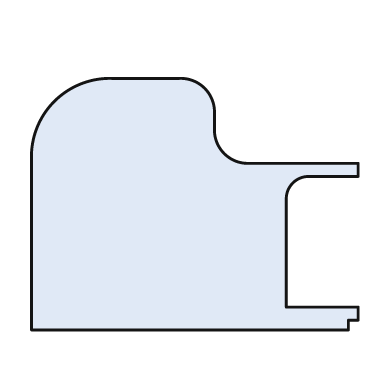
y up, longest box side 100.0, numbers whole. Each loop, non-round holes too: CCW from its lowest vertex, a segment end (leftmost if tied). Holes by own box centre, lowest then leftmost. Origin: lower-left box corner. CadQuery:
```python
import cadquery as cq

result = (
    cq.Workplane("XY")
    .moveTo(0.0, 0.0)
    .lineTo(97.0, 0.0)
    .lineTo(97.0, 3.0)
    .lineTo(100.0, 3.0)
    .lineTo(100.0, 7.0)
    .lineTo(78.0, 7.0)
    .lineTo(78.0, 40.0)
    .threePointArc((80.0, 45.0), (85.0, 47.0))
    .lineTo(100.0, 47.0)
    .lineTo(100.0, 51.0)
    .lineTo(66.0, 51.0)
    .threePointArc((59.0, 54.0), (56.0, 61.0))
    .lineTo(56.0, 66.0)
    .threePointArc((53.0, 74.0), (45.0, 77.0))
    .lineTo(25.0, 77.0)
    .threePointArc((7.0, 70.0), (0.0, 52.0))
    .close()
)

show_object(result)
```